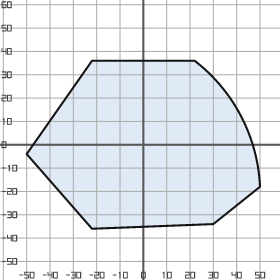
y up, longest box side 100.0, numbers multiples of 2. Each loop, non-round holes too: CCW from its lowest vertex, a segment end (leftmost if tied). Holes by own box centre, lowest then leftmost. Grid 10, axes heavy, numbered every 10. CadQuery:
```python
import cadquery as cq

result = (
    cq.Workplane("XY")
    .moveTo(-22.0, -36.0)
    .lineTo(30.0, -34.0)
    .lineTo(50.0, -18.0)
    .threePointArc((42.0, 12.0), (22.0, 36.0))
    .lineTo(-22.0, 36.0)
    .lineTo(-50.0, -4.0)
    .close()
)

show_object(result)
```